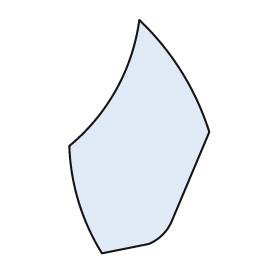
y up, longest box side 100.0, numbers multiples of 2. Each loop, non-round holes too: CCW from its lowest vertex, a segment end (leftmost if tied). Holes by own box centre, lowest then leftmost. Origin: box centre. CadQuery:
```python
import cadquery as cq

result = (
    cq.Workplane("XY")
    .moveTo(-16.0, -50.0)
    .lineTo(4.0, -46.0)
    .threePointArc((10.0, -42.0), (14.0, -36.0))
    .lineTo(30.0, 2.0)
    .threePointArc((18.0, 28.0), (0.0, 50.0))
    .threePointArc((-10.0, 20.0), (-30.0, -4.0))
    .threePointArc((-26.0, -28.0), (-16.0, -50.0))
    .close()
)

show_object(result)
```